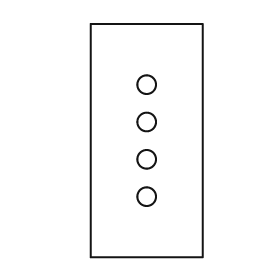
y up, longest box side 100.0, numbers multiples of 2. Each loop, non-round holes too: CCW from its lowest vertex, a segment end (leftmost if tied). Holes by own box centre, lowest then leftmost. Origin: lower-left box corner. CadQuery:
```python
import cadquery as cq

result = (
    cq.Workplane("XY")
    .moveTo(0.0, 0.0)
    .lineTo(48.0, 0.0)
    .lineTo(48.0, 100.0)
    .lineTo(0.0, 100.0)
    .close()
    .moveTo(24.0, 26.0)
    .circle(4.0)
    .moveTo(24.0, 42.0)
    .circle(4.0)
    .moveTo(24.0, 58.0)
    .circle(4.0)
    .moveTo(24.0, 74.0)
    .circle(4.0)
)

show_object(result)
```